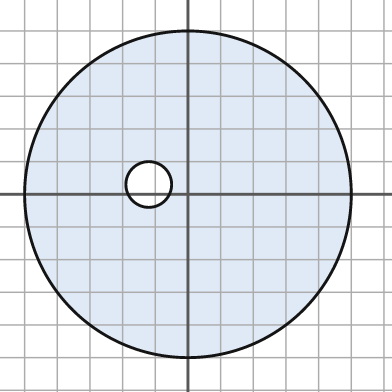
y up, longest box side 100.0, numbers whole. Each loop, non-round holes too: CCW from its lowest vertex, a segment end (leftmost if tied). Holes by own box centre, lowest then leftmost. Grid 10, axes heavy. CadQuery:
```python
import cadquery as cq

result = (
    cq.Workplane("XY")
    .moveTo(0.0, 0.0)
    .circle(50.0)
    .moveTo(-12.0, 3.0)
    .circle(7.0)
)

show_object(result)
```